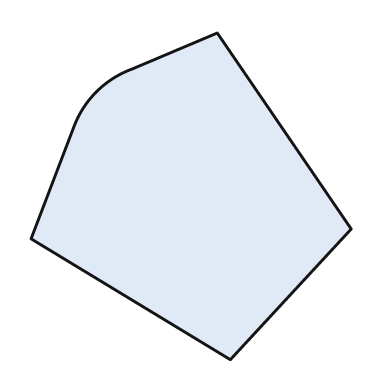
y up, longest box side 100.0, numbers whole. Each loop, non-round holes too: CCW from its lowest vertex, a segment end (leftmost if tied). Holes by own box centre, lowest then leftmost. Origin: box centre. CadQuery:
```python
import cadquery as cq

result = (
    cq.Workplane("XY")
    .moveTo(12.0, -50.0)
    .lineTo(49.0, -10.0)
    .lineTo(8.0, 50.0)
    .lineTo(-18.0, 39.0)
    .threePointArc((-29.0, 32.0), (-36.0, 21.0))
    .lineTo(-49.0, -13.0)
    .close()
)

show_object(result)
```